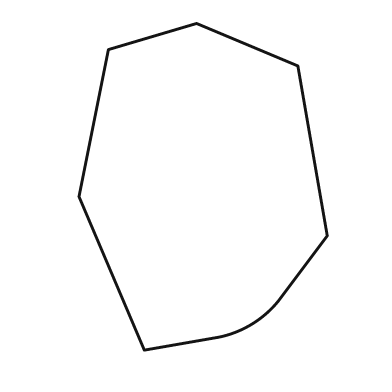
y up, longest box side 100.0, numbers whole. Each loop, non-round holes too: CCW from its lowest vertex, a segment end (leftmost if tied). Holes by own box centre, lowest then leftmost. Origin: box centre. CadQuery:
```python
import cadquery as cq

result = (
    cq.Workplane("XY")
    .moveTo(-18.0, -50.0)
    .lineTo(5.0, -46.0)
    .threePointArc((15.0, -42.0), (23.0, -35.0))
    .lineTo(38.0, -15.0)
    .lineTo(29.0, 37.0)
    .lineTo(-2.0, 50.0)
    .lineTo(-29.0, 42.0)
    .lineTo(-38.0, -3.0)
    .close()
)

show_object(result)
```